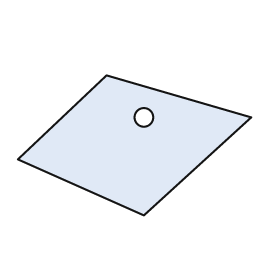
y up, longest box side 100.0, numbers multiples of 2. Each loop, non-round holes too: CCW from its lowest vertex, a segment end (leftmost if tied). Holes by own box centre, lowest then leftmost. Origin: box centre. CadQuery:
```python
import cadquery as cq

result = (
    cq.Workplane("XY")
    .moveTo(4.0, -30.0)
    .lineTo(50.0, 12.0)
    .lineTo(-12.0, 30.0)
    .lineTo(-50.0, -6.0)
    .close()
    .moveTo(4.0, 12.0)
    .circle(4.0)
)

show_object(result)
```